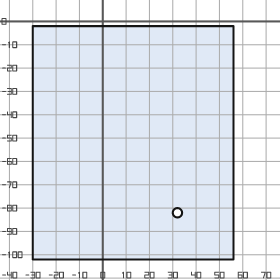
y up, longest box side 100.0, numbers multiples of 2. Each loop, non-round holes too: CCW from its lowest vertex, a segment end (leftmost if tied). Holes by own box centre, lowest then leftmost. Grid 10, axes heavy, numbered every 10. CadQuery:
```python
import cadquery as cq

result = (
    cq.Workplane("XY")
    .moveTo(-30.0, -102.0)
    .lineTo(56.0, -102.0)
    .lineTo(56.0, -2.0)
    .lineTo(-30.0, -2.0)
    .close()
    .moveTo(32.0, -82.0)
    .circle(2.0)
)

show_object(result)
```